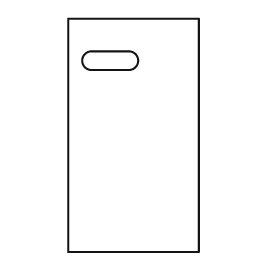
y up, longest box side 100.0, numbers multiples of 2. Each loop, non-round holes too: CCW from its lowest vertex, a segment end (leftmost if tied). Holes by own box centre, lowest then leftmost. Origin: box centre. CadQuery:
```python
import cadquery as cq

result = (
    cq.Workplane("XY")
    .moveTo(-28.0, -50.0)
    .lineTo(28.0, -50.0)
    .lineTo(28.0, 50.0)
    .lineTo(-28.0, 50.0)
    .close()
    .moveTo(-18.0, 28.0)
    .lineTo(-2.0, 28.0)
    .threePointArc((2.0, 32.0), (-2.0, 36.0))
    .lineTo(-18.0, 36.0)
    .threePointArc((-22.0, 32.0), (-18.0, 28.0))
    .close()
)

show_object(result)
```